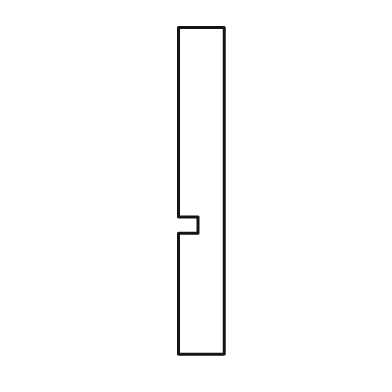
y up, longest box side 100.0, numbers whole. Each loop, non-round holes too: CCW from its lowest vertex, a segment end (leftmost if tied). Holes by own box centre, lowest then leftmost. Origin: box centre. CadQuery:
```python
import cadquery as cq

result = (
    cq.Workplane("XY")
    .moveTo(-7.0, -50.0)
    .lineTo(7.0, -50.0)
    .lineTo(7.0, 50.0)
    .lineTo(-7.0, 50.0)
    .lineTo(-7.0, -8.0)
    .lineTo(-1.0, -8.0)
    .lineTo(-1.0, -13.0)
    .lineTo(-7.0, -13.0)
    .close()
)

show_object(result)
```